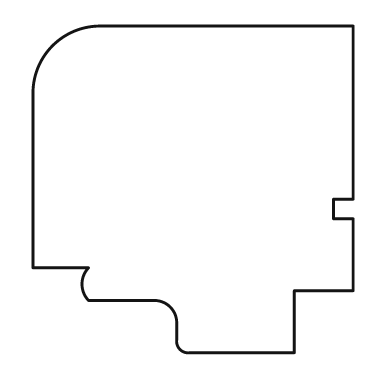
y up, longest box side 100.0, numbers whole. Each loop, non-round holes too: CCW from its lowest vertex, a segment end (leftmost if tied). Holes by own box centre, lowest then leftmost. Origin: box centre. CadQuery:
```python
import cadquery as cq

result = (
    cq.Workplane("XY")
    .moveTo(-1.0, -50.0)
    .lineTo(31.0, -50.0)
    .lineTo(31.0, -31.0)
    .lineTo(49.0, -31.0)
    .lineTo(49.0, -9.0)
    .lineTo(43.0, -9.0)
    .lineTo(43.0, -3.0)
    .lineTo(49.0, -3.0)
    .lineTo(49.0, 50.0)
    .lineTo(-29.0, 50.0)
    .threePointArc((-43.0, 44.0), (-49.0, 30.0))
    .lineTo(-49.0, -24.0)
    .lineTo(-32.0, -24.0)
    .threePointArc((-34.0, -29.0), (-32.0, -34.0))
    .lineTo(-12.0, -34.0)
    .threePointArc((-7.0, -36.0), (-5.0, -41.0))
    .lineTo(-5.0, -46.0)
    .threePointArc((-4.0, -49.0), (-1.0, -50.0))
    .close()
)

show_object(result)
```